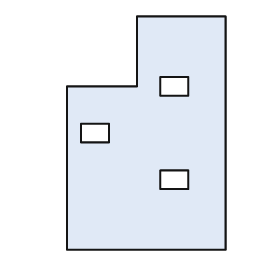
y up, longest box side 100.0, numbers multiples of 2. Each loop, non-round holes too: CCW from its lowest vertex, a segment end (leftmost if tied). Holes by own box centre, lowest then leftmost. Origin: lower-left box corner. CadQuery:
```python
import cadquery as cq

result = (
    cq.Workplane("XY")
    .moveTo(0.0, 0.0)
    .lineTo(68.0, 0.0)
    .lineTo(68.0, 100.0)
    .lineTo(30.0, 100.0)
    .lineTo(30.0, 70.0)
    .lineTo(0.0, 70.0)
    .close()
    .moveTo(40.0, 26.0)
    .lineTo(52.0, 26.0)
    .lineTo(52.0, 34.0)
    .lineTo(40.0, 34.0)
    .close()
    .moveTo(6.0, 46.0)
    .lineTo(18.0, 46.0)
    .lineTo(18.0, 54.0)
    .lineTo(6.0, 54.0)
    .close()
    .moveTo(40.0, 66.0)
    .lineTo(52.0, 66.0)
    .lineTo(52.0, 74.0)
    .lineTo(40.0, 74.0)
    .close()
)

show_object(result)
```